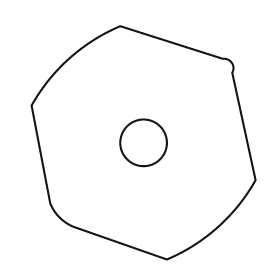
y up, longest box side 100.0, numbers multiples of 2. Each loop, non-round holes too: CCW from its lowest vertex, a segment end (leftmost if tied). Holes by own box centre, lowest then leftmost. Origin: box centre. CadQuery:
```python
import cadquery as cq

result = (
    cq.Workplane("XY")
    .moveTo(10.0, -50.0)
    .threePointArc((32.0, -36.0), (48.0, -16.0))
    .lineTo(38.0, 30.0)
    .threePointArc((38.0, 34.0), (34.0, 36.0))
    .lineTo(-10.0, 50.0)
    .threePointArc((-32.0, 36.0), (-48.0, 16.0))
    .lineTo(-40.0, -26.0)
    .threePointArc((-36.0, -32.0), (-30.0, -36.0))
    .close()
    .moveTo(0.0, 0.0)
    .circle(10.0)
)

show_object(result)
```